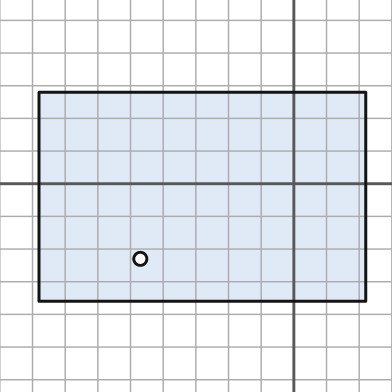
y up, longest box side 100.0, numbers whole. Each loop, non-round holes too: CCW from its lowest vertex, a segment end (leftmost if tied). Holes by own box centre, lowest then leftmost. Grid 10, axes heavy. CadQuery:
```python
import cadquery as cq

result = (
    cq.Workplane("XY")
    .moveTo(-78.0, -36.0)
    .lineTo(22.0, -36.0)
    .lineTo(22.0, 28.0)
    .lineTo(-78.0, 28.0)
    .close()
    .moveTo(-47.0, -23.0)
    .circle(2.0)
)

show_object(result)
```